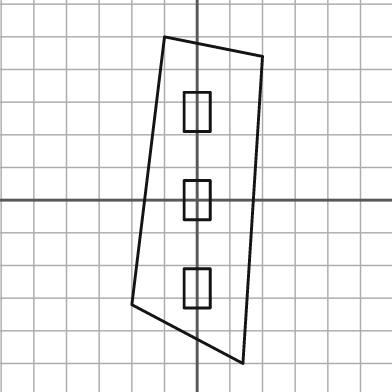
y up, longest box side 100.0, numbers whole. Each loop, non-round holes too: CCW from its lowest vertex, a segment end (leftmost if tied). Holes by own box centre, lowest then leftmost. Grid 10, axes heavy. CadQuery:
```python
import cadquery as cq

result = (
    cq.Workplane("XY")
    .moveTo(14.0, -50.0)
    .lineTo(20.0, 44.0)
    .lineTo(-10.0, 50.0)
    .lineTo(-20.0, -32.0)
    .close()
    .moveTo(-4.0, -33.0)
    .lineTo(4.0, -33.0)
    .lineTo(4.0, -21.0)
    .lineTo(-4.0, -21.0)
    .close()
    .moveTo(-4.0, -6.0)
    .lineTo(4.0, -6.0)
    .lineTo(4.0, 6.0)
    .lineTo(-4.0, 6.0)
    .close()
    .moveTo(-4.0, 21.0)
    .lineTo(4.0, 21.0)
    .lineTo(4.0, 33.0)
    .lineTo(-4.0, 33.0)
    .close()
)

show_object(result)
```